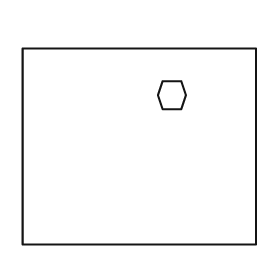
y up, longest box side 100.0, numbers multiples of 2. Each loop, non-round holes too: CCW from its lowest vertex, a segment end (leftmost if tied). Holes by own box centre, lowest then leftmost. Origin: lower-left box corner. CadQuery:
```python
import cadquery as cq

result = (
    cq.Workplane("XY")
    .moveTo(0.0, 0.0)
    .lineTo(100.0, 0.0)
    .lineTo(100.0, 84.0)
    .lineTo(0.0, 84.0)
    .close()
    .moveTo(60.0, 58.0)
    .lineTo(68.0, 58.0)
    .lineTo(70.0, 64.0)
    .lineTo(68.0, 70.0)
    .lineTo(60.0, 70.0)
    .lineTo(58.0, 64.0)
    .close()
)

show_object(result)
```